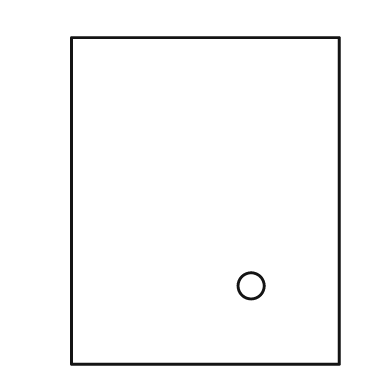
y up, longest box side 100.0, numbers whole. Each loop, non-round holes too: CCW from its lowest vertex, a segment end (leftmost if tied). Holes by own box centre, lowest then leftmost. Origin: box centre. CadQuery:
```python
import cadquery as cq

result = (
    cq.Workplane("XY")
    .moveTo(-41.0, -50.0)
    .lineTo(41.0, -50.0)
    .lineTo(41.0, 50.0)
    .lineTo(-41.0, 50.0)
    .close()
    .moveTo(14.0, -26.0)
    .circle(4.0)
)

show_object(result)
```